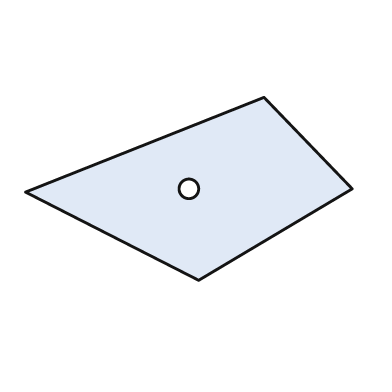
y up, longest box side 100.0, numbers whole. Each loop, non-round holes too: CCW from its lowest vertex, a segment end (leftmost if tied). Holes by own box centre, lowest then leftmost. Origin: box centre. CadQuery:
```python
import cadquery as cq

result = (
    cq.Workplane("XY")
    .moveTo(3.0, -28.0)
    .lineTo(50.0, 0.0)
    .lineTo(23.0, 28.0)
    .lineTo(-50.0, -1.0)
    .close()
    .moveTo(0.0, 0.0)
    .circle(3.0)
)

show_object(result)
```